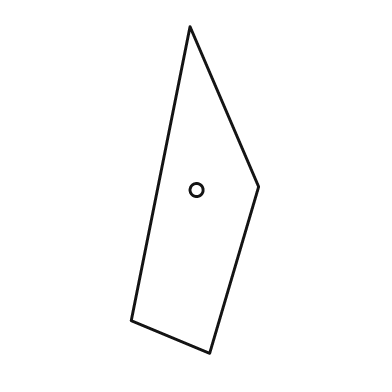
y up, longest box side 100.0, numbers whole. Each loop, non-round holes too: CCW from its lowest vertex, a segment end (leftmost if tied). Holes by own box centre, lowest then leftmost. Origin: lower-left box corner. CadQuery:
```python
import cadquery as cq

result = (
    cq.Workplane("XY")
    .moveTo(24.0, 0.0)
    .lineTo(39.0, 51.0)
    .lineTo(18.0, 100.0)
    .lineTo(0.0, 10.0)
    .close()
    .moveTo(20.0, 50.0)
    .circle(2.0)
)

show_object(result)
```